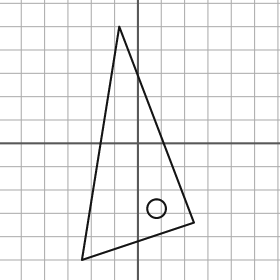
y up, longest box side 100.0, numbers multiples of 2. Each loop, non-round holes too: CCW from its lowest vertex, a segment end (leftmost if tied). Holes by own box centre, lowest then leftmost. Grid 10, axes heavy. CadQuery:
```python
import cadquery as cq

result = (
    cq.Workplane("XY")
    .moveTo(-24.0, -50.0)
    .lineTo(24.0, -34.0)
    .lineTo(-8.0, 50.0)
    .close()
    .moveTo(8.0, -28.0)
    .circle(4.0)
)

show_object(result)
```